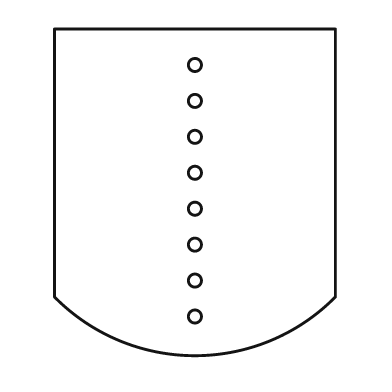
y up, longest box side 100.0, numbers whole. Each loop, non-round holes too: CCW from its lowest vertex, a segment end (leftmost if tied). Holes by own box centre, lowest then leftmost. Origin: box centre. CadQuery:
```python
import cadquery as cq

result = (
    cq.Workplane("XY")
    .moveTo(-43.0, -32.0)
    .threePointArc((0.0, -50.0), (43.0, -32.0))
    .lineTo(43.0, 50.0)
    .lineTo(-43.0, 50.0)
    .close()
    .moveTo(0.0, -38.0)
    .circle(2.0)
    .moveTo(0.0, -27.0)
    .circle(2.0)
    .moveTo(0.0, -16.0)
    .circle(2.0)
    .moveTo(0.0, -5.0)
    .circle(2.0)
    .moveTo(0.0, 6.0)
    .circle(2.0)
    .moveTo(0.0, 17.0)
    .circle(2.0)
    .moveTo(0.0, 28.0)
    .circle(2.0)
    .moveTo(0.0, 39.0)
    .circle(2.0)
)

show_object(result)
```